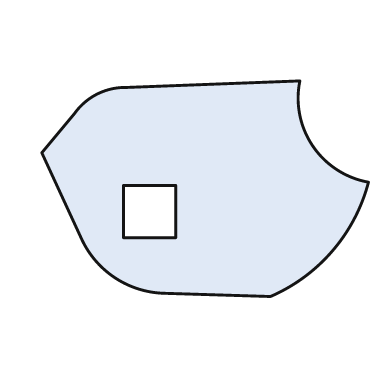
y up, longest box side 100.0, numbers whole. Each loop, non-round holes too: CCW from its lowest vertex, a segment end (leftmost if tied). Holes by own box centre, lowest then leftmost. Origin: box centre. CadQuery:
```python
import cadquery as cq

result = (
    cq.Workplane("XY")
    .moveTo(20.0, -33.0)
    .threePointArc((39.0, -19.0), (50.0, 2.0))
    .threePointArc((33.0, 13.0), (29.0, 33.0))
    .lineTo(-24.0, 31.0)
    .threePointArc((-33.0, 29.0), (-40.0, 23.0))
    .lineTo(-50.0, 11.0)
    .lineTo(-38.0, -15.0)
    .threePointArc((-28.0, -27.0), (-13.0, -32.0))
    .close()
    .moveTo(-25.0, -15.0)
    .lineTo(-9.0, -15.0)
    .lineTo(-9.0, 1.0)
    .lineTo(-25.0, 1.0)
    .close()
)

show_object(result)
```